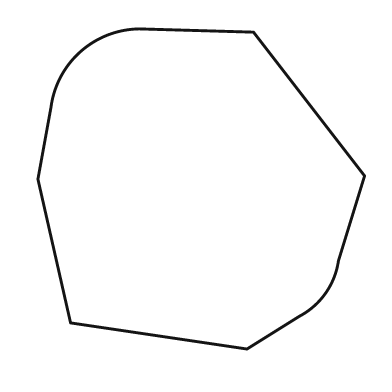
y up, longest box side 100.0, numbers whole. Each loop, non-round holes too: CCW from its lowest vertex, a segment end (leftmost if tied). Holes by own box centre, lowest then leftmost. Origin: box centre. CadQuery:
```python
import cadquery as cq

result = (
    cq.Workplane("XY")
    .moveTo(14.0, -49.0)
    .lineTo(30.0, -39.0)
    .threePointArc((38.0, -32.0), (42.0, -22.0))
    .lineTo(50.0, 4.0)
    .lineTo(16.0, 48.0)
    .lineTo(-19.0, 49.0)
    .threePointArc((-37.0, 42.0), (-46.0, 25.0))
    .lineTo(-50.0, 3.0)
    .lineTo(-40.0, -41.0)
    .close()
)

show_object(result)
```